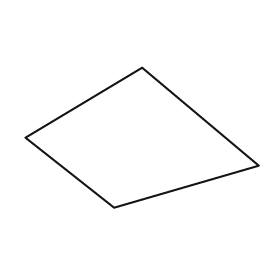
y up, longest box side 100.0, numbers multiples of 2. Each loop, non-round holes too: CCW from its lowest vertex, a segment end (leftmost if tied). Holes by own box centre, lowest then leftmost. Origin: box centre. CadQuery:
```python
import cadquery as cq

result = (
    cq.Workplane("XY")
    .moveTo(-12.0, -30.0)
    .lineTo(50.0, -12.0)
    .lineTo(0.0, 30.0)
    .lineTo(-50.0, 0.0)
    .close()
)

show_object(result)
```